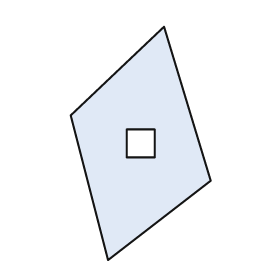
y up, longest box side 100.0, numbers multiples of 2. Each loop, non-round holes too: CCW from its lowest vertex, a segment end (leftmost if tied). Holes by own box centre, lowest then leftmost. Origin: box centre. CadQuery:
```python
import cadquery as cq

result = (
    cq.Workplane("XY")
    .moveTo(-14.0, -50.0)
    .lineTo(30.0, -16.0)
    .lineTo(10.0, 50.0)
    .lineTo(-30.0, 12.0)
    .close()
    .moveTo(-6.0, -6.0)
    .lineTo(6.0, -6.0)
    .lineTo(6.0, 6.0)
    .lineTo(-6.0, 6.0)
    .close()
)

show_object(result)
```